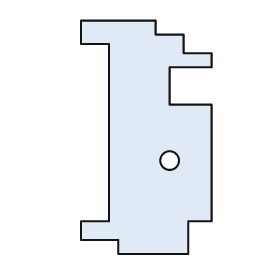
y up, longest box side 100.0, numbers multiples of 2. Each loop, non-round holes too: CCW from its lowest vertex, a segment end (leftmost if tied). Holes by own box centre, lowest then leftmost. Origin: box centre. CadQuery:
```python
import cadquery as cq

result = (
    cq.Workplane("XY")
    .moveTo(-12.0, -50.0)
    .lineTo(18.0, -50.0)
    .lineTo(18.0, -36.0)
    .lineTo(28.0, -36.0)
    .lineTo(28.0, 14.0)
    .lineTo(10.0, 14.0)
    .lineTo(10.0, 30.0)
    .lineTo(28.0, 30.0)
    .lineTo(28.0, 36.0)
    .lineTo(16.0, 36.0)
    .lineTo(16.0, 44.0)
    .lineTo(4.0, 44.0)
    .lineTo(4.0, 50.0)
    .lineTo(-28.0, 50.0)
    .lineTo(-28.0, 40.0)
    .lineTo(-16.0, 40.0)
    .lineTo(-16.0, -36.0)
    .lineTo(-28.0, -36.0)
    .lineTo(-28.0, -44.0)
    .lineTo(-12.0, -44.0)
    .close()
    .moveTo(10.0, -10.0)
    .circle(4.0)
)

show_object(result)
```